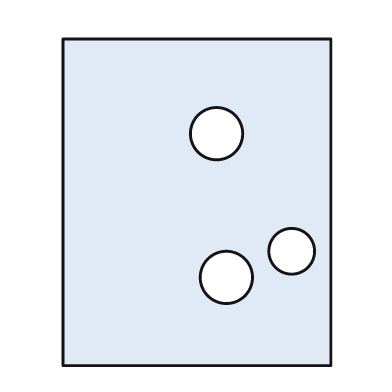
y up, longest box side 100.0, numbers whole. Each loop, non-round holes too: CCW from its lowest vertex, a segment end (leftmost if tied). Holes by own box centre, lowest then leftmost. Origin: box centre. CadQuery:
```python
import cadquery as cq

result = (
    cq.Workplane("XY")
    .moveTo(-41.0, -50.0)
    .lineTo(41.0, -50.0)
    .lineTo(41.0, 50.0)
    .lineTo(-41.0, 50.0)
    .close()
    .moveTo(9.0, -23.0)
    .circle(8.0)
    .moveTo(29.0, -15.0)
    .circle(7.0)
    .moveTo(6.0, 21.0)
    .circle(8.0)
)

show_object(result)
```